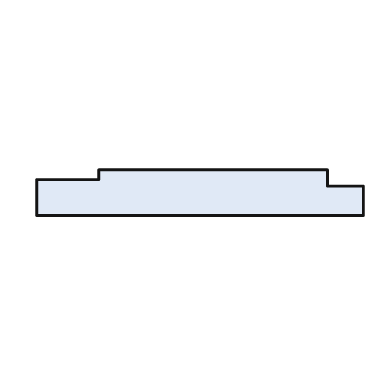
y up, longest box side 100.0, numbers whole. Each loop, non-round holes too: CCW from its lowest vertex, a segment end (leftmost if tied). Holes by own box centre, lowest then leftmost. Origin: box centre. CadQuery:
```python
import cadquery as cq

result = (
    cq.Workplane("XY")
    .moveTo(-50.0, -7.0)
    .lineTo(50.0, -7.0)
    .lineTo(50.0, 2.0)
    .lineTo(39.0, 2.0)
    .lineTo(39.0, 7.0)
    .lineTo(-31.0, 7.0)
    .lineTo(-31.0, 4.0)
    .lineTo(-50.0, 4.0)
    .close()
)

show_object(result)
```